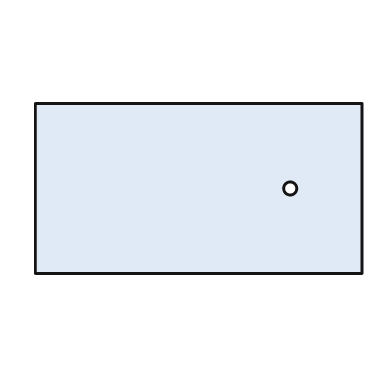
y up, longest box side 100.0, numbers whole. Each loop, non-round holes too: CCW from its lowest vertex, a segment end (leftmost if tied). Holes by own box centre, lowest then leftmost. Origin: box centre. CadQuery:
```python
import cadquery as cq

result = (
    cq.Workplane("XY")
    .moveTo(-50.0, -26.0)
    .lineTo(50.0, -26.0)
    .lineTo(50.0, 26.0)
    .lineTo(-50.0, 26.0)
    .close()
    .moveTo(28.0, 0.0)
    .circle(2.0)
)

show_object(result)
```